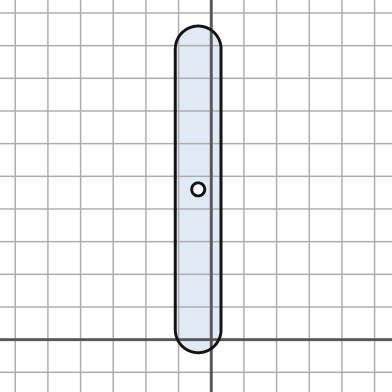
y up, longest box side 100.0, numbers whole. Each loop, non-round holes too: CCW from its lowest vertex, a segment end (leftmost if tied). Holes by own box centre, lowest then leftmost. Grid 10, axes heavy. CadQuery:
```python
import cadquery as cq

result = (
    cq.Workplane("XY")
    .moveTo(-11.0, 3.0)
    .threePointArc((-4.0, -4.0), (3.0, 3.0))
    .lineTo(3.0, 89.0)
    .threePointArc((-4.0, 96.0), (-11.0, 89.0))
    .close()
    .moveTo(-4.0, 46.0)
    .circle(2.0)
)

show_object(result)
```